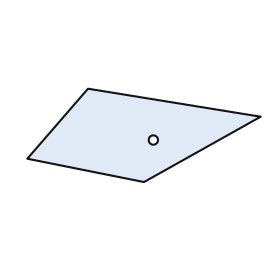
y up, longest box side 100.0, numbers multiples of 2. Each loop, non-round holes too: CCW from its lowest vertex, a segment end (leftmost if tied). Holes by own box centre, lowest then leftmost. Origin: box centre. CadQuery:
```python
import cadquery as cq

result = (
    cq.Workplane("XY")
    .moveTo(0.0, -20.0)
    .lineTo(50.0, 8.0)
    .lineTo(-24.0, 20.0)
    .lineTo(-50.0, -10.0)
    .close()
    .moveTo(4.0, -2.0)
    .circle(2.0)
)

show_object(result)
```